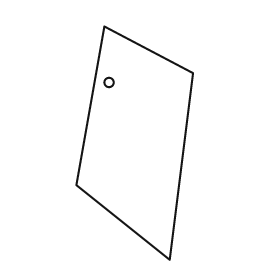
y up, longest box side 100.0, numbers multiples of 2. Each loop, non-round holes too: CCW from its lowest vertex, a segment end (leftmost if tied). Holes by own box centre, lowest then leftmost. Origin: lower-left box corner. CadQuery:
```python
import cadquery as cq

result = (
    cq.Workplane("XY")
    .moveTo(40.0, 0.0)
    .lineTo(50.0, 80.0)
    .lineTo(12.0, 100.0)
    .lineTo(0.0, 32.0)
    .close()
    .moveTo(14.0, 76.0)
    .circle(2.0)
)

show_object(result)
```